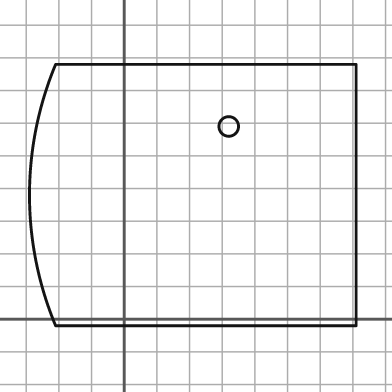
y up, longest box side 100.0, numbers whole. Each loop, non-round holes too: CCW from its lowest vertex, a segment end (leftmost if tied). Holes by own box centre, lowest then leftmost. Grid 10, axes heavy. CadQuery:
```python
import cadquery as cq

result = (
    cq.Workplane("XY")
    .moveTo(-21.0, -2.0)
    .lineTo(71.0, -2.0)
    .lineTo(71.0, 78.0)
    .lineTo(-21.0, 78.0)
    .threePointArc((-29.0, 38.0), (-21.0, -2.0))
    .close()
    .moveTo(32.0, 59.0)
    .circle(3.0)
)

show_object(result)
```